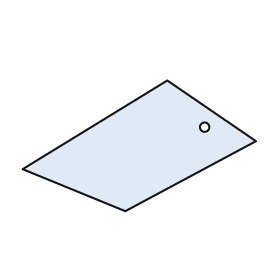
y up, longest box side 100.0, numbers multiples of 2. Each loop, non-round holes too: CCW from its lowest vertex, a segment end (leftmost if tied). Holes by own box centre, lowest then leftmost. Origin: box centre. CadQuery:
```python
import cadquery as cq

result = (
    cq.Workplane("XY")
    .moveTo(-6.0, -28.0)
    .lineTo(50.0, 2.0)
    .lineTo(12.0, 28.0)
    .lineTo(-50.0, -10.0)
    .close()
    .moveTo(28.0, 8.0)
    .circle(2.0)
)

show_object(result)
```